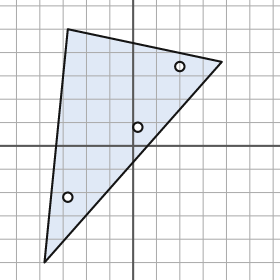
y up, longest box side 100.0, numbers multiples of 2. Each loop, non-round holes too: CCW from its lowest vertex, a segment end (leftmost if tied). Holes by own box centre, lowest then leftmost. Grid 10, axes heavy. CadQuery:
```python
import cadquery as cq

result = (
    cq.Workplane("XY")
    .moveTo(-38.0, -50.0)
    .lineTo(38.0, 36.0)
    .lineTo(-28.0, 50.0)
    .close()
    .moveTo(-28.0, -22.0)
    .circle(2.0)
    .moveTo(2.0, 8.0)
    .circle(2.0)
    .moveTo(20.0, 34.0)
    .circle(2.0)
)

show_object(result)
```